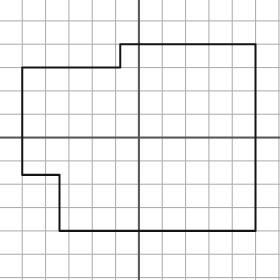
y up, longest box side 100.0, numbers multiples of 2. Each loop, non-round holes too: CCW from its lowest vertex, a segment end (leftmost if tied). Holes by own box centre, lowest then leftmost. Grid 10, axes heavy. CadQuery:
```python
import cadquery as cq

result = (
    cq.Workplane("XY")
    .moveTo(-34.0, -40.0)
    .lineTo(50.0, -40.0)
    .lineTo(50.0, 40.0)
    .lineTo(-8.0, 40.0)
    .lineTo(-8.0, 30.0)
    .lineTo(-50.0, 30.0)
    .lineTo(-50.0, -16.0)
    .lineTo(-34.0, -16.0)
    .close()
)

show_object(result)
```